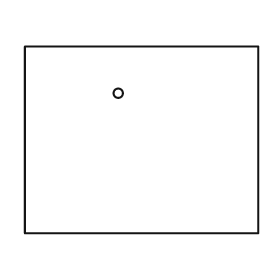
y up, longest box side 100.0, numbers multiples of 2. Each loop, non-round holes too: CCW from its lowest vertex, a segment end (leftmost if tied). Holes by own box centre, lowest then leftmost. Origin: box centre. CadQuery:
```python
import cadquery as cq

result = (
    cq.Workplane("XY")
    .moveTo(-50.0, -40.0)
    .lineTo(50.0, -40.0)
    .lineTo(50.0, 40.0)
    .lineTo(-50.0, 40.0)
    .close()
    .moveTo(-10.0, 20.0)
    .circle(2.0)
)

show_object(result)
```